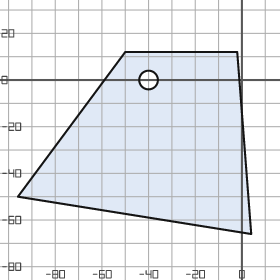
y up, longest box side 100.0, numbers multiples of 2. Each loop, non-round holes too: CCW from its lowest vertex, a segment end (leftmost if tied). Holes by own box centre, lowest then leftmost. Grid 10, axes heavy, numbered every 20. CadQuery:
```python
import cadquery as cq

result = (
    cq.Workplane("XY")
    .moveTo(4.0, -66.0)
    .lineTo(-2.0, 12.0)
    .lineTo(-50.0, 12.0)
    .lineTo(-96.0, -50.0)
    .close()
    .moveTo(-40.0, 0.0)
    .circle(4.0)
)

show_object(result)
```